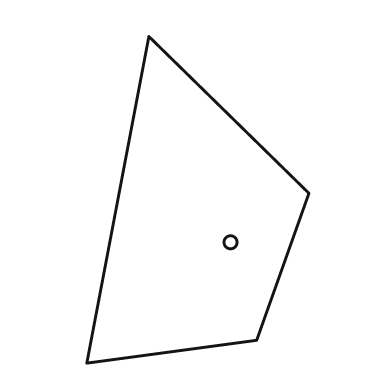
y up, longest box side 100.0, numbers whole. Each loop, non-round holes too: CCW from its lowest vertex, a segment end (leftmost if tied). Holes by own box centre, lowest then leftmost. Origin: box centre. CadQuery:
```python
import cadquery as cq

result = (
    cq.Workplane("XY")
    .moveTo(-34.0, -50.0)
    .lineTo(18.0, -43.0)
    .lineTo(34.0, 2.0)
    .lineTo(-15.0, 50.0)
    .close()
    .moveTo(10.0, -13.0)
    .circle(2.0)
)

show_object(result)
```